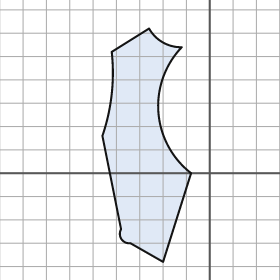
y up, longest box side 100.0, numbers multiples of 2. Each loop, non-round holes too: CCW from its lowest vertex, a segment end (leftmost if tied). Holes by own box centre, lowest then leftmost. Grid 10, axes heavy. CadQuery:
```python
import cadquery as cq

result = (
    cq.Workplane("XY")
    .moveTo(-20.0, -38.0)
    .lineTo(-8.0, 0.0)
    .threePointArc((-22.0, 26.0), (-12.0, 54.0))
    .threePointArc((-20.0, 56.0), (-26.0, 62.0))
    .lineTo(-42.0, 52.0)
    .threePointArc((-42.0, 34.0), (-46.0, 16.0))
    .lineTo(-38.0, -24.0)
    .threePointArc((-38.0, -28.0), (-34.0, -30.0))
    .close()
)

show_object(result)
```